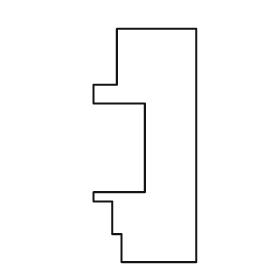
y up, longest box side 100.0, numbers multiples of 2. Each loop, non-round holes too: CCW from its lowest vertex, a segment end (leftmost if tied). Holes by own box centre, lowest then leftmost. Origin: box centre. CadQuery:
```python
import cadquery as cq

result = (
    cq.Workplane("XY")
    .moveTo(-10.0, -50.0)
    .lineTo(22.0, -50.0)
    .lineTo(22.0, 50.0)
    .lineTo(-12.0, 50.0)
    .lineTo(-12.0, 26.0)
    .lineTo(-22.0, 26.0)
    .lineTo(-22.0, 18.0)
    .lineTo(0.0, 18.0)
    .lineTo(0.0, -20.0)
    .lineTo(-22.0, -20.0)
    .lineTo(-22.0, -24.0)
    .lineTo(-14.0, -24.0)
    .lineTo(-14.0, -38.0)
    .lineTo(-10.0, -38.0)
    .close()
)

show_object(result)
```